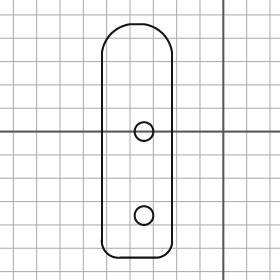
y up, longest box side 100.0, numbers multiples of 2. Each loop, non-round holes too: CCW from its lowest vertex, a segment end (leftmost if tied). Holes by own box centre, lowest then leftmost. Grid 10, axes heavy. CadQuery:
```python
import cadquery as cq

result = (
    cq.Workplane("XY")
    .moveTo(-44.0, -54.0)
    .lineTo(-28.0, -54.0)
    .threePointArc((-24.0, -52.0), (-22.0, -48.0))
    .lineTo(-22.0, 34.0)
    .threePointArc((-26.0, 42.0), (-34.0, 46.0))
    .lineTo(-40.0, 46.0)
    .threePointArc((-48.0, 42.0), (-52.0, 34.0))
    .lineTo(-52.0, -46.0)
    .threePointArc((-50.0, -52.0), (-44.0, -54.0))
    .close()
    .moveTo(-34.0, -36.0)
    .circle(4.0)
    .moveTo(-34.0, 0.0)
    .circle(4.0)
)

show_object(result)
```